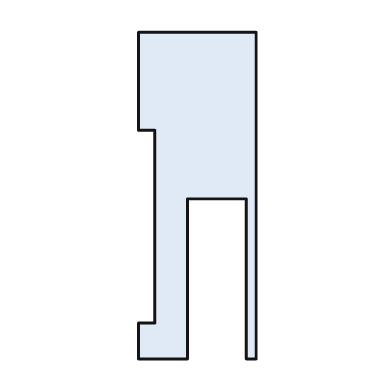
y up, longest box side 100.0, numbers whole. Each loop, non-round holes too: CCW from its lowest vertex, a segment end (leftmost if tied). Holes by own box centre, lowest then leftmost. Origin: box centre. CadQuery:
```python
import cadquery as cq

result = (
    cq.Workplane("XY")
    .moveTo(-18.0, -50.0)
    .lineTo(-3.0, -50.0)
    .lineTo(-3.0, -1.0)
    .lineTo(15.0, -1.0)
    .lineTo(15.0, -50.0)
    .lineTo(18.0, -50.0)
    .lineTo(18.0, 50.0)
    .lineTo(-18.0, 50.0)
    .lineTo(-18.0, 20.0)
    .lineTo(-13.0, 20.0)
    .lineTo(-13.0, -39.0)
    .lineTo(-18.0, -39.0)
    .close()
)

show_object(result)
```